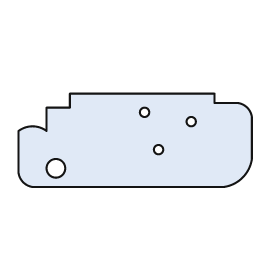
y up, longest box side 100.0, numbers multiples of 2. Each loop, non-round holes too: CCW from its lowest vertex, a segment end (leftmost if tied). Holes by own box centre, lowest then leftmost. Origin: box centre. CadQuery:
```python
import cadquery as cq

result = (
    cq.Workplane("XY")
    .moveTo(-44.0, -20.0)
    .lineTo(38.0, -20.0)
    .threePointArc((46.0, -16.0), (50.0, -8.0))
    .lineTo(50.0, 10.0)
    .threePointArc((48.0, 14.0), (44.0, 16.0))
    .lineTo(34.0, 16.0)
    .lineTo(34.0, 20.0)
    .lineTo(-28.0, 20.0)
    .lineTo(-28.0, 14.0)
    .lineTo(-38.0, 14.0)
    .lineTo(-38.0, 4.0)
    .threePointArc((-44.0, 6.0), (-50.0, 4.0))
    .lineTo(-50.0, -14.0)
    .threePointArc((-48.0, -18.0), (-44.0, -20.0))
    .close()
    .moveTo(-34.0, -12.0)
    .circle(4.0)
    .moveTo(10.0, -4.0)
    .circle(2.0)
    .moveTo(24.0, 8.0)
    .circle(2.0)
    .moveTo(4.0, 12.0)
    .circle(2.0)
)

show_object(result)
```